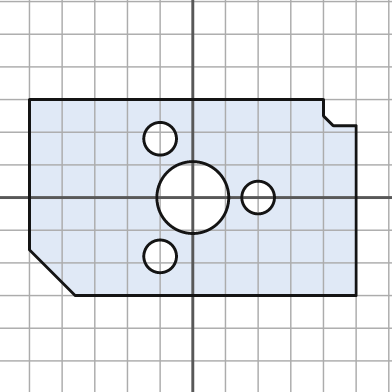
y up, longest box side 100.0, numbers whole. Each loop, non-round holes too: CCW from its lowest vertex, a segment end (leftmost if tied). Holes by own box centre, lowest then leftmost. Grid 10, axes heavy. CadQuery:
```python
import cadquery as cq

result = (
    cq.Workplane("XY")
    .moveTo(-36.0, -30.0)
    .lineTo(50.0, -30.0)
    .lineTo(50.0, 22.0)
    .lineTo(43.0, 22.0)
    .lineTo(40.0, 25.0)
    .lineTo(40.0, 30.0)
    .lineTo(-50.0, 30.0)
    .lineTo(-50.0, -16.0)
    .close()
    .moveTo(-10.0, -18.0)
    .circle(5.0)
    .moveTo(0.0, 0.0)
    .circle(11.0)
    .moveTo(20.0, 0.0)
    .circle(5.0)
    .moveTo(-10.0, 18.0)
    .circle(5.0)
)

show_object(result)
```